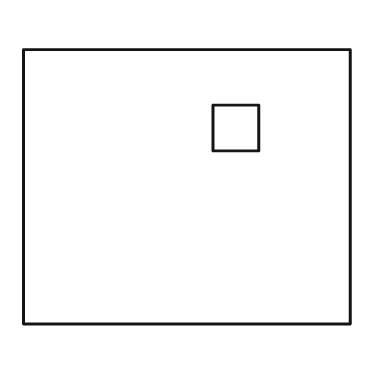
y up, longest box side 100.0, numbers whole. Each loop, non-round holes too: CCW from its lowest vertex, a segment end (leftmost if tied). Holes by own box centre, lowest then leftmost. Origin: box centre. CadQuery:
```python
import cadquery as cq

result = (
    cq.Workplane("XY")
    .moveTo(-50.0, -42.0)
    .lineTo(50.0, -42.0)
    .lineTo(50.0, 42.0)
    .lineTo(-50.0, 42.0)
    .close()
    .moveTo(8.0, 11.0)
    .lineTo(22.0, 11.0)
    .lineTo(22.0, 25.0)
    .lineTo(8.0, 25.0)
    .close()
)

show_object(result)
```